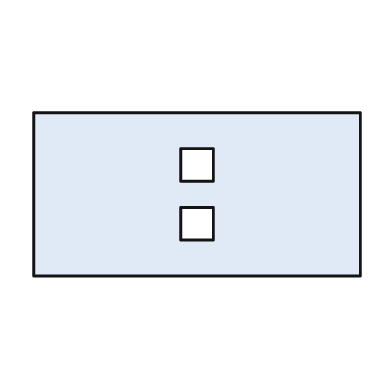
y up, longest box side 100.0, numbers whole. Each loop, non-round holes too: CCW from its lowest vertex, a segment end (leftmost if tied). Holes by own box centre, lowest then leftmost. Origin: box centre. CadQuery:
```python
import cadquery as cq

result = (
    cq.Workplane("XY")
    .moveTo(-50.0, -25.0)
    .lineTo(50.0, -25.0)
    .lineTo(50.0, 25.0)
    .lineTo(-50.0, 25.0)
    .close()
    .moveTo(-5.0, -14.0)
    .lineTo(5.0, -14.0)
    .lineTo(5.0, -4.0)
    .lineTo(-5.0, -4.0)
    .close()
    .moveTo(-5.0, 4.0)
    .lineTo(5.0, 4.0)
    .lineTo(5.0, 14.0)
    .lineTo(-5.0, 14.0)
    .close()
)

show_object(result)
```